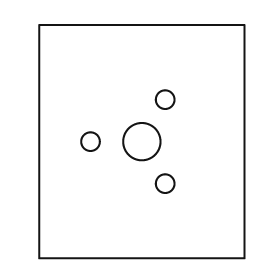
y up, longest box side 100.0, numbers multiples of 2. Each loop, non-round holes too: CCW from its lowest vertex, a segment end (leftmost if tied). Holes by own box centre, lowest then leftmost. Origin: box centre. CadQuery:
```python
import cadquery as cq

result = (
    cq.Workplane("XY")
    .moveTo(-44.0, -50.0)
    .lineTo(44.0, -50.0)
    .lineTo(44.0, 50.0)
    .lineTo(-44.0, 50.0)
    .close()
    .moveTo(10.0, -18.0)
    .circle(4.0)
    .moveTo(-22.0, 0.0)
    .circle(4.0)
    .moveTo(0.0, 0.0)
    .circle(8.0)
    .moveTo(10.0, 18.0)
    .circle(4.0)
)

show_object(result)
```